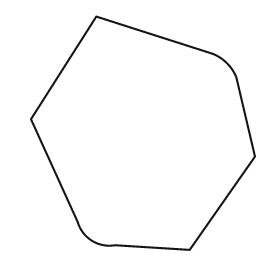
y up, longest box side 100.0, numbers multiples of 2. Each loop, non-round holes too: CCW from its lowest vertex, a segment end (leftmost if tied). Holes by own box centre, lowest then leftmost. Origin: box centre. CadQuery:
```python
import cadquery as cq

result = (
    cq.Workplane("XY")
    .moveTo(20.0, -50.0)
    .lineTo(48.0, -10.0)
    .lineTo(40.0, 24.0)
    .threePointArc((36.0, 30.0), (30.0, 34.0))
    .lineTo(-20.0, 50.0)
    .lineTo(-48.0, 6.0)
    .lineTo(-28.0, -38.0)
    .threePointArc((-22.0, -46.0), (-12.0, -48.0))
    .close()
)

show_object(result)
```